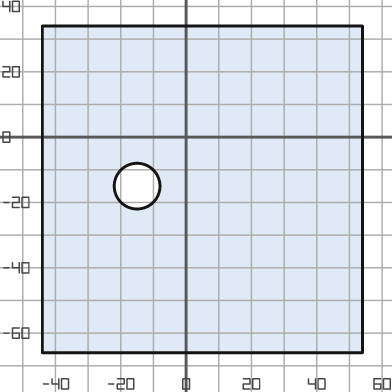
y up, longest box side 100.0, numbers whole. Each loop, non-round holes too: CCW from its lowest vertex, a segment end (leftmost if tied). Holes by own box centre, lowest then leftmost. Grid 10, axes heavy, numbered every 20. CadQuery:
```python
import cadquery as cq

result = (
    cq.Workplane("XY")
    .moveTo(-44.0, -66.0)
    .lineTo(54.0, -66.0)
    .lineTo(54.0, 34.0)
    .lineTo(-44.0, 34.0)
    .close()
    .moveTo(-15.0, -15.0)
    .circle(7.0)
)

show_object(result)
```